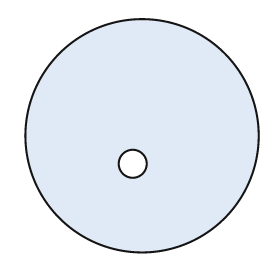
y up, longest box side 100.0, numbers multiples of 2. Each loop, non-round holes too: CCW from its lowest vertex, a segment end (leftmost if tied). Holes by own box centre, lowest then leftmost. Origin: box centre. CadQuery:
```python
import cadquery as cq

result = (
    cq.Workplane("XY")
    .moveTo(0.0, 0.0)
    .circle(50.0)
    .moveTo(-4.0, -12.0)
    .circle(6.0)
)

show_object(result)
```